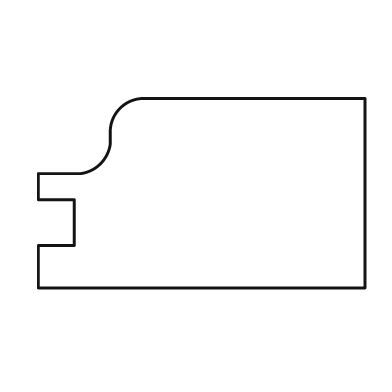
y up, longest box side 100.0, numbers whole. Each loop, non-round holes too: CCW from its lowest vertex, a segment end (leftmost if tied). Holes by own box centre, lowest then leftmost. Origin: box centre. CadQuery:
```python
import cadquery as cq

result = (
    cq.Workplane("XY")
    .moveTo(-50.0, -29.0)
    .lineTo(50.0, -29.0)
    .lineTo(50.0, 29.0)
    .lineTo(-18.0, 29.0)
    .threePointArc((-25.0, 26.0), (-28.0, 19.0))
    .lineTo(-28.0, 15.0)
    .threePointArc((-31.0, 9.0), (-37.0, 6.0))
    .lineTo(-50.0, 6.0)
    .lineTo(-50.0, -2.0)
    .lineTo(-39.0, -2.0)
    .lineTo(-39.0, -16.0)
    .lineTo(-50.0, -16.0)
    .close()
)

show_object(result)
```